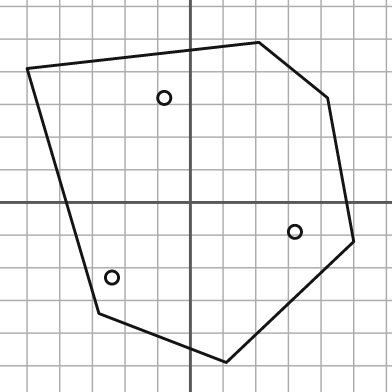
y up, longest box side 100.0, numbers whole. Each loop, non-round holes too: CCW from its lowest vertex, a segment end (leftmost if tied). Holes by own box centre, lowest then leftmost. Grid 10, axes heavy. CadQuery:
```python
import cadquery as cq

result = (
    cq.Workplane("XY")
    .moveTo(11.0, -49.0)
    .lineTo(50.0, -12.0)
    .lineTo(42.0, 32.0)
    .lineTo(21.0, 49.0)
    .lineTo(-50.0, 41.0)
    .lineTo(-28.0, -34.0)
    .close()
    .moveTo(-24.0, -23.0)
    .circle(2.0)
    .moveTo(32.0, -9.0)
    .circle(2.0)
    .moveTo(-8.0, 32.0)
    .circle(2.0)
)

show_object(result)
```